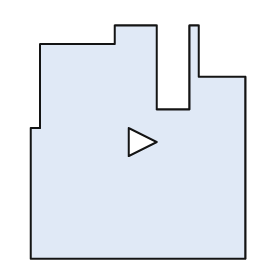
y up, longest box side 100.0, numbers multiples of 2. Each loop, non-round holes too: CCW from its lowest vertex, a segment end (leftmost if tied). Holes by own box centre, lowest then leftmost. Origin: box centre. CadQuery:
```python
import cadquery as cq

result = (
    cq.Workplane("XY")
    .moveTo(-46.0, -50.0)
    .lineTo(46.0, -50.0)
    .lineTo(46.0, 28.0)
    .lineTo(26.0, 28.0)
    .lineTo(26.0, 50.0)
    .lineTo(22.0, 50.0)
    .lineTo(22.0, 14.0)
    .lineTo(8.0, 14.0)
    .lineTo(8.0, 50.0)
    .lineTo(-10.0, 50.0)
    .lineTo(-10.0, 42.0)
    .lineTo(-42.0, 42.0)
    .lineTo(-42.0, 6.0)
    .lineTo(-46.0, 6.0)
    .close()
    .moveTo(-4.0, -6.0)
    .lineTo(8.0, 0.0)
    .lineTo(-4.0, 6.0)
    .close()
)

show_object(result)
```